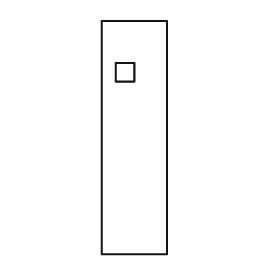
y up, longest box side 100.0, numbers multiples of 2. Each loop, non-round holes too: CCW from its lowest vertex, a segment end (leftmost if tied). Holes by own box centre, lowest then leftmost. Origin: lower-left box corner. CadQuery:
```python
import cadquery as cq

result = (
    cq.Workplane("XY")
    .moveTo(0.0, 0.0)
    .lineTo(28.0, 0.0)
    .lineTo(28.0, 100.0)
    .lineTo(0.0, 100.0)
    .close()
    .moveTo(6.0, 74.0)
    .lineTo(14.0, 74.0)
    .lineTo(14.0, 82.0)
    .lineTo(6.0, 82.0)
    .close()
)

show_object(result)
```